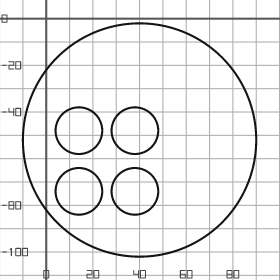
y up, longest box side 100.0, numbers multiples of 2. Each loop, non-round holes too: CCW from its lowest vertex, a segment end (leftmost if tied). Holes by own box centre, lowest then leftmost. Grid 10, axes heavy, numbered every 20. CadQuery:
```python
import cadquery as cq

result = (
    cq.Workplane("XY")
    .moveTo(40.0, -52.0)
    .circle(50.0)
    .moveTo(14.0, -74.0)
    .circle(10.0)
    .moveTo(38.0, -74.0)
    .circle(10.0)
    .moveTo(14.0, -48.0)
    .circle(10.0)
    .moveTo(38.0, -48.0)
    .circle(10.0)
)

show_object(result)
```